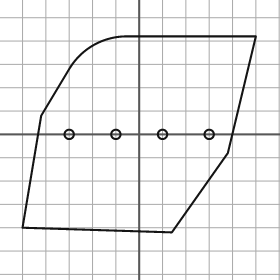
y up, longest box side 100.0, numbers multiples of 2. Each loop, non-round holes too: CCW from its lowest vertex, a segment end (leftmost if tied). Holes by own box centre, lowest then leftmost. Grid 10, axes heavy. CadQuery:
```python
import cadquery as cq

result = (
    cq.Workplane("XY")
    .moveTo(14.0, -42.0)
    .lineTo(38.0, -8.0)
    .lineTo(50.0, 42.0)
    .lineTo(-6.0, 42.0)
    .threePointArc((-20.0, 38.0), (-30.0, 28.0))
    .lineTo(-42.0, 8.0)
    .lineTo(-50.0, -40.0)
    .close()
    .moveTo(-30.0, 0.0)
    .circle(2.0)
    .moveTo(-10.0, 0.0)
    .circle(2.0)
    .moveTo(10.0, 0.0)
    .circle(2.0)
    .moveTo(30.0, 0.0)
    .circle(2.0)
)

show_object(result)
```